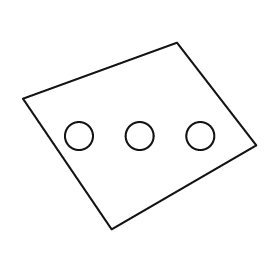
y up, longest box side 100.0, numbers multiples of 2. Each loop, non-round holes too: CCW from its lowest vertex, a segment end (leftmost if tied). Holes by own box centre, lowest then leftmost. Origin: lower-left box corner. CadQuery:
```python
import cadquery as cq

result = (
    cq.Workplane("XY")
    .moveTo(38.0, 0.0)
    .lineTo(100.0, 36.0)
    .lineTo(66.0, 80.0)
    .lineTo(0.0, 56.0)
    .close()
    .moveTo(24.0, 40.0)
    .circle(6.0)
    .moveTo(50.0, 40.0)
    .circle(6.0)
    .moveTo(76.0, 40.0)
    .circle(6.0)
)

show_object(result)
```